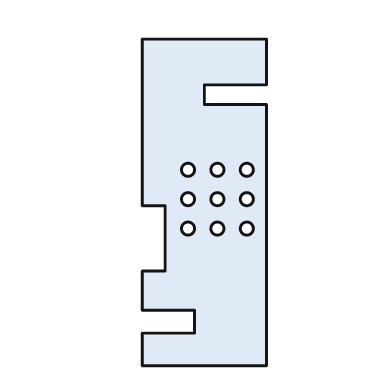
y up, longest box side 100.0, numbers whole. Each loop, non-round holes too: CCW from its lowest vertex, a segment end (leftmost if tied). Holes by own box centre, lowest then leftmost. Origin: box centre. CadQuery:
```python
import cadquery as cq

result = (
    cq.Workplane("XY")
    .moveTo(-19.0, -50.0)
    .lineTo(19.0, -50.0)
    .lineTo(19.0, 30.0)
    .lineTo(0.0, 30.0)
    .lineTo(0.0, 36.0)
    .lineTo(19.0, 36.0)
    .lineTo(19.0, 50.0)
    .lineTo(-19.0, 50.0)
    .lineTo(-19.0, -1.0)
    .lineTo(-12.0, -1.0)
    .lineTo(-12.0, -21.0)
    .lineTo(-19.0, -21.0)
    .lineTo(-19.0, -33.0)
    .lineTo(-3.0, -33.0)
    .lineTo(-3.0, -40.0)
    .lineTo(-19.0, -40.0)
    .close()
    .moveTo(-5.0, -8.0)
    .circle(2.0)
    .moveTo(4.0, -8.0)
    .circle(2.0)
    .moveTo(13.0, -8.0)
    .circle(2.0)
    .moveTo(-5.0, 1.0)
    .circle(2.0)
    .moveTo(4.0, 1.0)
    .circle(2.0)
    .moveTo(13.0, 1.0)
    .circle(2.0)
    .moveTo(-5.0, 10.0)
    .circle(2.0)
    .moveTo(4.0, 10.0)
    .circle(2.0)
    .moveTo(13.0, 10.0)
    .circle(2.0)
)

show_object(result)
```